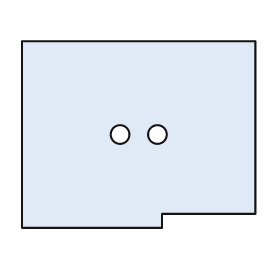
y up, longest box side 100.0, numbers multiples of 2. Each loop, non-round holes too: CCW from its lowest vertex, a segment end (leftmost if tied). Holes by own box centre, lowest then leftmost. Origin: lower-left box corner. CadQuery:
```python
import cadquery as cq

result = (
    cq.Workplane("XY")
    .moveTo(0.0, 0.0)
    .lineTo(60.0, 0.0)
    .lineTo(60.0, 6.0)
    .lineTo(100.0, 6.0)
    .lineTo(100.0, 80.0)
    .lineTo(0.0, 80.0)
    .close()
    .moveTo(42.0, 40.0)
    .circle(4.0)
    .moveTo(58.0, 40.0)
    .circle(4.0)
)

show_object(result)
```